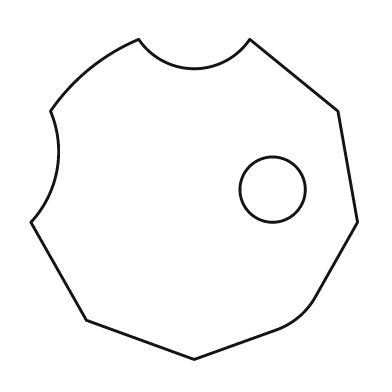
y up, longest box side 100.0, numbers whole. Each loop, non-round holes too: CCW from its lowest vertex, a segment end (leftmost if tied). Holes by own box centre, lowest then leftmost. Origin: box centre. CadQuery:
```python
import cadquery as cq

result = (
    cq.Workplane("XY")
    .moveTo(0.0, -49.0)
    .lineTo(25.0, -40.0)
    .threePointArc((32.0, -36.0), (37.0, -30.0))
    .lineTo(50.0, -7.0)
    .lineTo(44.0, 27.0)
    .lineTo(17.0, 49.0)
    .threePointArc((0.0, 40.0), (-17.0, 49.0))
    .threePointArc((-32.0, 40.0), (-44.0, 27.0))
    .threePointArc((-42.0, 9.0), (-50.0, -7.0))
    .lineTo(-33.0, -37.0)
    .close()
    .moveTo(24.0, 3.0)
    .circle(10.0)
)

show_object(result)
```